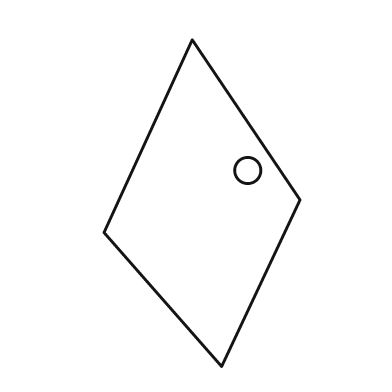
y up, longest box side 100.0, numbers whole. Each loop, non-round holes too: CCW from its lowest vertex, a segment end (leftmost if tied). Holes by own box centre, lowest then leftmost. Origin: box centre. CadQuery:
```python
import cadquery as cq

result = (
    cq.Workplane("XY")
    .moveTo(6.0, -50.0)
    .lineTo(30.0, 1.0)
    .lineTo(-3.0, 50.0)
    .lineTo(-30.0, -9.0)
    .close()
    .moveTo(14.0, 10.0)
    .circle(4.0)
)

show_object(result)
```